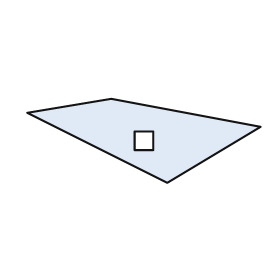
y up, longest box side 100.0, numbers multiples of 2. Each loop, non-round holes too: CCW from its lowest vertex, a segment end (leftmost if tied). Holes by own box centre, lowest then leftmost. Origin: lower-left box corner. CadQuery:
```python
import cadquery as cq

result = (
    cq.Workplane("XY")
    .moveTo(60.0, 0.0)
    .lineTo(100.0, 24.0)
    .lineTo(36.0, 36.0)
    .lineTo(0.0, 30.0)
    .close()
    .moveTo(46.0, 14.0)
    .lineTo(54.0, 14.0)
    .lineTo(54.0, 22.0)
    .lineTo(46.0, 22.0)
    .close()
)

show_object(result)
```